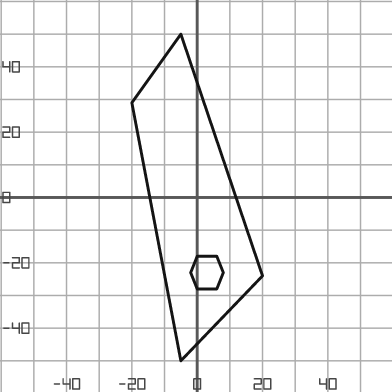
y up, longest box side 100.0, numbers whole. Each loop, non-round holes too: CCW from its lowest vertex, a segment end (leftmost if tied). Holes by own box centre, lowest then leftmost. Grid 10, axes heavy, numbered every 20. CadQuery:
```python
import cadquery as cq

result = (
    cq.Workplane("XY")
    .moveTo(-5.0, -50.0)
    .lineTo(20.0, -24.0)
    .lineTo(-5.0, 50.0)
    .lineTo(-20.0, 29.0)
    .close()
    .moveTo(0.0, -28.0)
    .lineTo(6.0, -28.0)
    .lineTo(8.0, -23.0)
    .lineTo(6.0, -18.0)
    .lineTo(0.0, -18.0)
    .lineTo(-2.0, -23.0)
    .close()
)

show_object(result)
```